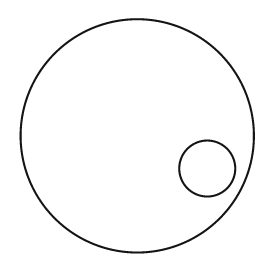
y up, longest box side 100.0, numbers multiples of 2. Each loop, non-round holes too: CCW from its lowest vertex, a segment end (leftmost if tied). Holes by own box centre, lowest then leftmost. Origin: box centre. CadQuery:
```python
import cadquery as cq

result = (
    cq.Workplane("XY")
    .moveTo(0.0, 0.0)
    .circle(50.0)
    .moveTo(30.0, -14.0)
    .circle(12.0)
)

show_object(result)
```